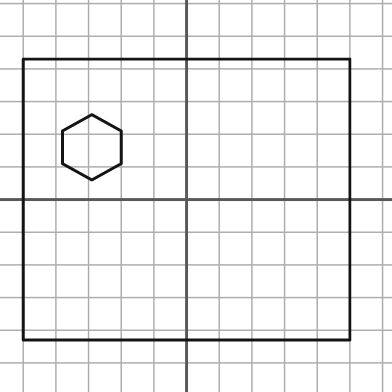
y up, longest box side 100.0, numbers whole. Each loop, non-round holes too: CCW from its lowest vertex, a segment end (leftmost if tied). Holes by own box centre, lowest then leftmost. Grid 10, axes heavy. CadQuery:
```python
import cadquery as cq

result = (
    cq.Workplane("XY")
    .moveTo(-50.0, -43.0)
    .lineTo(50.0, -43.0)
    .lineTo(50.0, 43.0)
    .lineTo(-50.0, 43.0)
    .close()
    .moveTo(-29.0, 6.0)
    .lineTo(-20.0, 11.0)
    .lineTo(-20.0, 21.0)
    .lineTo(-29.0, 26.0)
    .lineTo(-38.0, 21.0)
    .lineTo(-38.0, 11.0)
    .close()
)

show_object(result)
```